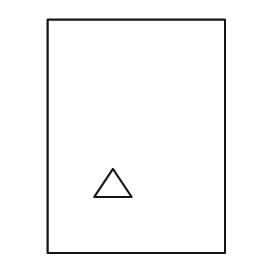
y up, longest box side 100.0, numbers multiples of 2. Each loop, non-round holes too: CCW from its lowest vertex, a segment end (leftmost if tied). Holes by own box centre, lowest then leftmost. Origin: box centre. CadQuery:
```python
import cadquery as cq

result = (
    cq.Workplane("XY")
    .moveTo(-38.0, -50.0)
    .lineTo(38.0, -50.0)
    .lineTo(38.0, 50.0)
    .lineTo(-38.0, 50.0)
    .close()
    .moveTo(-18.0, -26.0)
    .lineTo(-2.0, -26.0)
    .lineTo(-10.0, -14.0)
    .close()
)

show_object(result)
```